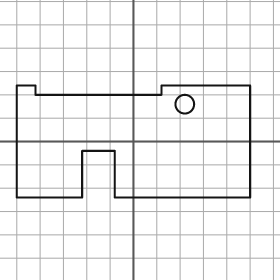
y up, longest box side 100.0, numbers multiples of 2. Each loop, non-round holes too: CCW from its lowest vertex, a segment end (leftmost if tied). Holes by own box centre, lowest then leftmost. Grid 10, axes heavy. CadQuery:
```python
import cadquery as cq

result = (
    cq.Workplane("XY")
    .moveTo(-50.0, -24.0)
    .lineTo(-22.0, -24.0)
    .lineTo(-22.0, -4.0)
    .lineTo(-8.0, -4.0)
    .lineTo(-8.0, -24.0)
    .lineTo(50.0, -24.0)
    .lineTo(50.0, 24.0)
    .lineTo(12.0, 24.0)
    .lineTo(12.0, 20.0)
    .lineTo(-42.0, 20.0)
    .lineTo(-42.0, 24.0)
    .lineTo(-50.0, 24.0)
    .close()
    .moveTo(22.0, 16.0)
    .circle(4.0)
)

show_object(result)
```